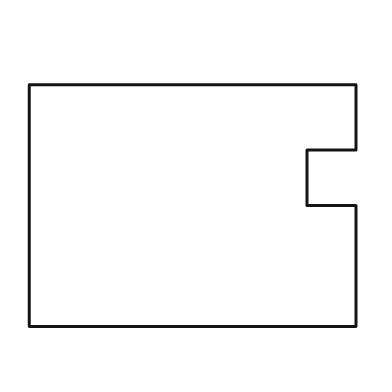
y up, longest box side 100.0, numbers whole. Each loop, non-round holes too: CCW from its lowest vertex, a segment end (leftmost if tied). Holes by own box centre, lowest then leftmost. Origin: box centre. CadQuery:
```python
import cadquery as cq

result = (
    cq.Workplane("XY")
    .moveTo(-50.0, -37.0)
    .lineTo(50.0, -37.0)
    .lineTo(50.0, 0.0)
    .lineTo(35.0, 0.0)
    .lineTo(35.0, 17.0)
    .lineTo(50.0, 17.0)
    .lineTo(50.0, 37.0)
    .lineTo(-50.0, 37.0)
    .close()
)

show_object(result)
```